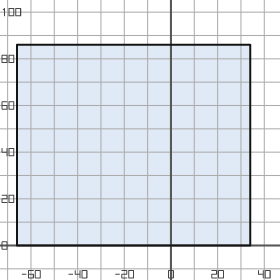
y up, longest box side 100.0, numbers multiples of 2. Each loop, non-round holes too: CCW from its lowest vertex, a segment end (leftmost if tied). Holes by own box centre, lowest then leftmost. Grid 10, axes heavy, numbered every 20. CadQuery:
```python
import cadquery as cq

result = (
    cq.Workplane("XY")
    .moveTo(-66.0, 0.0)
    .lineTo(34.0, 0.0)
    .lineTo(34.0, 86.0)
    .lineTo(-66.0, 86.0)
    .close()
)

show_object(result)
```